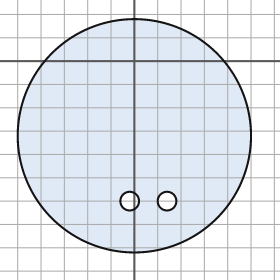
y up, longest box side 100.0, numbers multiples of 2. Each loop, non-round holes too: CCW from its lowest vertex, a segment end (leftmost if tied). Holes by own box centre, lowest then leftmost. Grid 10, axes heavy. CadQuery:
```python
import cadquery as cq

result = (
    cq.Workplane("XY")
    .moveTo(0.0, -32.0)
    .circle(50.0)
    .moveTo(-2.0, -60.0)
    .circle(4.0)
    .moveTo(14.0, -60.0)
    .circle(4.0)
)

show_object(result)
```